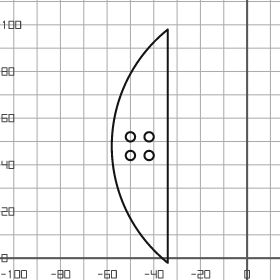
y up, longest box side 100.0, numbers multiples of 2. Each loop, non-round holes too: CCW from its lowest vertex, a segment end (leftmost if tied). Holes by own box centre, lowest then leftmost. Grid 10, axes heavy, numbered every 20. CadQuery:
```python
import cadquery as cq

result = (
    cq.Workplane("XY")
    .moveTo(-34.0, -2.0)
    .lineTo(-34.0, 98.0)
    .threePointArc((-58.0, 48.0), (-34.0, -2.0))
    .close()
    .moveTo(-50.0, 44.0)
    .circle(2.0)
    .moveTo(-42.0, 44.0)
    .circle(2.0)
    .moveTo(-50.0, 52.0)
    .circle(2.0)
    .moveTo(-42.0, 52.0)
    .circle(2.0)
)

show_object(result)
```